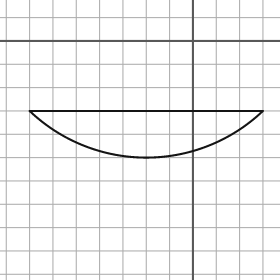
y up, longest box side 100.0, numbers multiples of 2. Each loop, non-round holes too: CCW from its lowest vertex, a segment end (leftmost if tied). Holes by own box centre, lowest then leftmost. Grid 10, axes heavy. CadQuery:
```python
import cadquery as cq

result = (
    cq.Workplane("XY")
    .moveTo(-70.0, -30.0)
    .threePointArc((-20.0, -50.0), (30.0, -30.0))
    .close()
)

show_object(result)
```